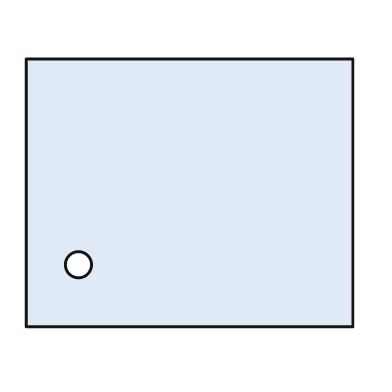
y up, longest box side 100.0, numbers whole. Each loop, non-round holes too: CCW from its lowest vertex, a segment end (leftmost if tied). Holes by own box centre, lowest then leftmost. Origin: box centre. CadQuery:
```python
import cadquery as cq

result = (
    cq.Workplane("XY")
    .moveTo(-50.0, -41.0)
    .lineTo(50.0, -41.0)
    .lineTo(50.0, 41.0)
    .lineTo(-50.0, 41.0)
    .close()
    .moveTo(-34.0, -22.0)
    .circle(4.0)
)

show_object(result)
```